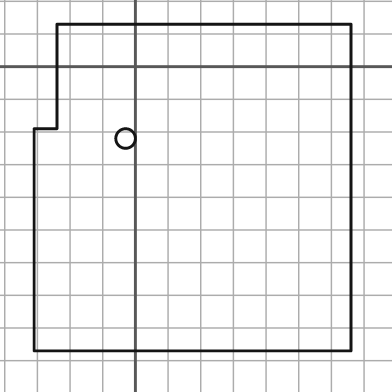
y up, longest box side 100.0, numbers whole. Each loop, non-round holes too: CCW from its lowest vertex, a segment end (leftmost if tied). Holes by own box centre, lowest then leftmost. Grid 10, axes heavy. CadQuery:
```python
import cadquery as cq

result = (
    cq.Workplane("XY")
    .moveTo(-31.0, -87.0)
    .lineTo(66.0, -87.0)
    .lineTo(66.0, 13.0)
    .lineTo(-24.0, 13.0)
    .lineTo(-24.0, -19.0)
    .lineTo(-31.0, -19.0)
    .close()
    .moveTo(-3.0, -22.0)
    .circle(3.0)
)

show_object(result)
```